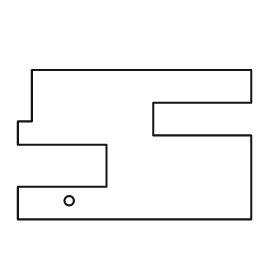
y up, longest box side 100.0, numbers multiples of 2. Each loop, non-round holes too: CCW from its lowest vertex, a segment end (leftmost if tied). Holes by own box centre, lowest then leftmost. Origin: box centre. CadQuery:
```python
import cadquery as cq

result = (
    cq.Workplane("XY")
    .moveTo(-50.0, -32.0)
    .lineTo(50.0, -32.0)
    .lineTo(50.0, 4.0)
    .lineTo(8.0, 4.0)
    .lineTo(8.0, 18.0)
    .lineTo(50.0, 18.0)
    .lineTo(50.0, 32.0)
    .lineTo(-44.0, 32.0)
    .lineTo(-44.0, 10.0)
    .lineTo(-50.0, 10.0)
    .lineTo(-50.0, 0.0)
    .lineTo(-12.0, 0.0)
    .lineTo(-12.0, -18.0)
    .lineTo(-50.0, -18.0)
    .close()
    .moveTo(-28.0, -24.0)
    .circle(2.0)
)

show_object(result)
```